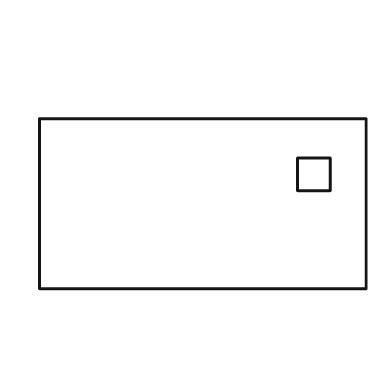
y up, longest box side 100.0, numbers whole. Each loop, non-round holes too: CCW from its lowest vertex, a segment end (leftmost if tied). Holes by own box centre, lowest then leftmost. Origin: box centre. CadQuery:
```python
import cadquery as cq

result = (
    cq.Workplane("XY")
    .moveTo(-50.0, -26.0)
    .lineTo(50.0, -26.0)
    .lineTo(50.0, 26.0)
    .lineTo(-50.0, 26.0)
    .close()
    .moveTo(29.0, 4.0)
    .lineTo(39.0, 4.0)
    .lineTo(39.0, 14.0)
    .lineTo(29.0, 14.0)
    .close()
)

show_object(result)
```